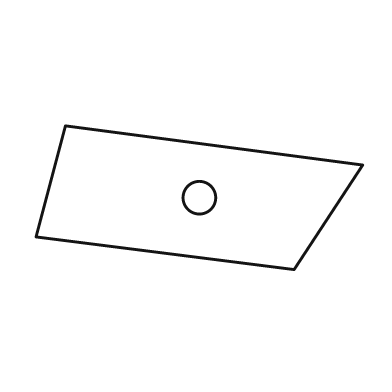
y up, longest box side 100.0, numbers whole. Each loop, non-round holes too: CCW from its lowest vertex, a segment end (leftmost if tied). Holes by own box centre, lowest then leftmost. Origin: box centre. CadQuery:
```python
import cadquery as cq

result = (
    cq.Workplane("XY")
    .moveTo(29.0, -22.0)
    .lineTo(50.0, 10.0)
    .lineTo(-41.0, 22.0)
    .lineTo(-50.0, -12.0)
    .close()
    .moveTo(0.0, 0.0)
    .circle(5.0)
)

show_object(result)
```